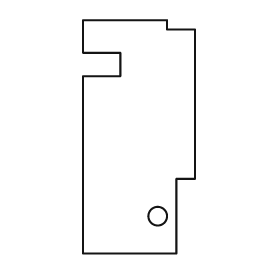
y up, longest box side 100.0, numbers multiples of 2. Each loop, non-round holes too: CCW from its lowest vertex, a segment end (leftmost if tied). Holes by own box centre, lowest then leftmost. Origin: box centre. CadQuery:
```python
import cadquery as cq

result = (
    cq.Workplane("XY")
    .moveTo(-24.0, -50.0)
    .lineTo(16.0, -50.0)
    .lineTo(16.0, -18.0)
    .lineTo(24.0, -18.0)
    .lineTo(24.0, 46.0)
    .lineTo(12.0, 46.0)
    .lineTo(12.0, 50.0)
    .lineTo(-24.0, 50.0)
    .lineTo(-24.0, 36.0)
    .lineTo(-8.0, 36.0)
    .lineTo(-8.0, 26.0)
    .lineTo(-24.0, 26.0)
    .close()
    .moveTo(8.0, -34.0)
    .circle(4.0)
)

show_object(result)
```